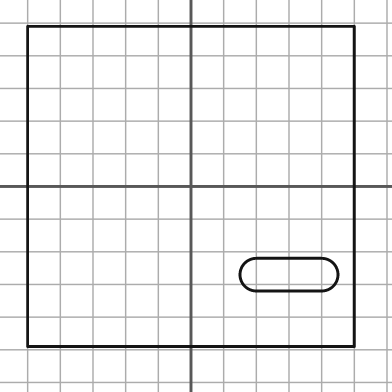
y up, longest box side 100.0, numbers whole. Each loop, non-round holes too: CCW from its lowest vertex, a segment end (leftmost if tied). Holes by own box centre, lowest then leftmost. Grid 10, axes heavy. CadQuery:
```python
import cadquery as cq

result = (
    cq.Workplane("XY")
    .moveTo(-50.0, -49.0)
    .lineTo(50.0, -49.0)
    .lineTo(50.0, 49.0)
    .lineTo(-50.0, 49.0)
    .close()
    .moveTo(20.0, -32.0)
    .lineTo(40.0, -32.0)
    .threePointArc((45.0, -27.0), (40.0, -22.0))
    .lineTo(20.0, -22.0)
    .threePointArc((15.0, -27.0), (20.0, -32.0))
    .close()
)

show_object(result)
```